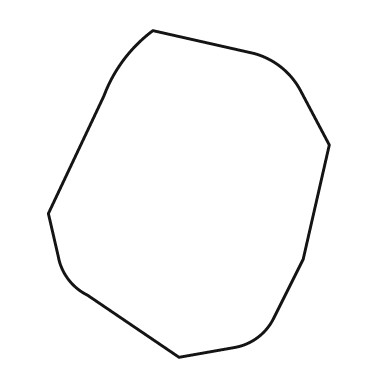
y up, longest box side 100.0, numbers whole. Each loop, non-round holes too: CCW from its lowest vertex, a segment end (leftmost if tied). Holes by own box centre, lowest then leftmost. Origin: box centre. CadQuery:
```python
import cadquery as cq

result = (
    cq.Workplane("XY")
    .moveTo(-3.0, -50.0)
    .lineTo(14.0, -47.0)
    .threePointArc((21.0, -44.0), (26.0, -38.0))
    .lineTo(35.0, -20.0)
    .lineTo(43.0, 15.0)
    .lineTo(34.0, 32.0)
    .threePointArc((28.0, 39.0), (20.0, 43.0))
    .lineTo(-11.0, 50.0)
    .threePointArc((-20.0, 41.0), (-26.0, 30.0))
    .lineTo(-43.0, -6.0)
    .lineTo(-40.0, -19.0)
    .threePointArc((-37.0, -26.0), (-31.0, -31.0))
    .close()
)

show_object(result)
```